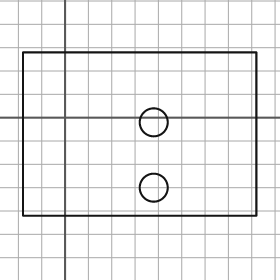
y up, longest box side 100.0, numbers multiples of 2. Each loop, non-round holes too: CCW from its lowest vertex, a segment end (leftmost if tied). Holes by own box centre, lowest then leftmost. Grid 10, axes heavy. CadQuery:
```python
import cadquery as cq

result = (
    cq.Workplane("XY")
    .moveTo(-18.0, -42.0)
    .lineTo(82.0, -42.0)
    .lineTo(82.0, 28.0)
    .lineTo(-18.0, 28.0)
    .close()
    .moveTo(38.0, -30.0)
    .circle(6.0)
    .moveTo(38.0, -2.0)
    .circle(6.0)
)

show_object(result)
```